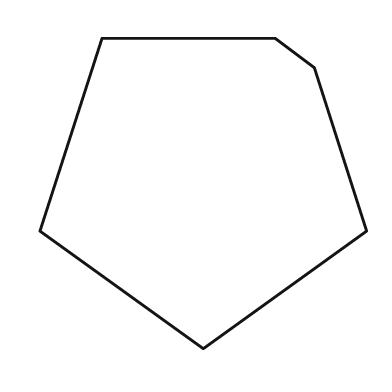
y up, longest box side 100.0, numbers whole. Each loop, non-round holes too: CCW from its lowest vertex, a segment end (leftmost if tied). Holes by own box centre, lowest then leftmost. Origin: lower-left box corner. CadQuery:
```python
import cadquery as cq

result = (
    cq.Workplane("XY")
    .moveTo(50.0, 0.0)
    .lineTo(100.0, 36.0)
    .lineTo(84.0, 86.0)
    .lineTo(72.0, 95.0)
    .lineTo(19.0, 95.0)
    .lineTo(0.0, 36.0)
    .close()
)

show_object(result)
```